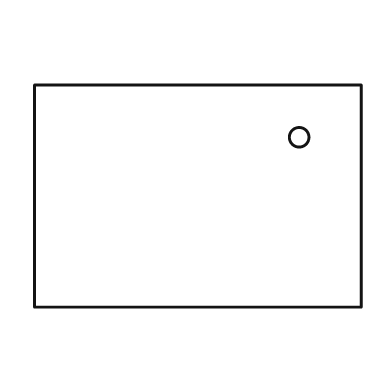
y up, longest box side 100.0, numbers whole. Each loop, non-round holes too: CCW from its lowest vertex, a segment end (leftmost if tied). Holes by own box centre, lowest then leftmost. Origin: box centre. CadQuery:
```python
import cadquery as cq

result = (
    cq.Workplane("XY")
    .moveTo(-50.0, -34.0)
    .lineTo(50.0, -34.0)
    .lineTo(50.0, 34.0)
    .lineTo(-50.0, 34.0)
    .close()
    .moveTo(31.0, 18.0)
    .circle(3.0)
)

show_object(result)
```